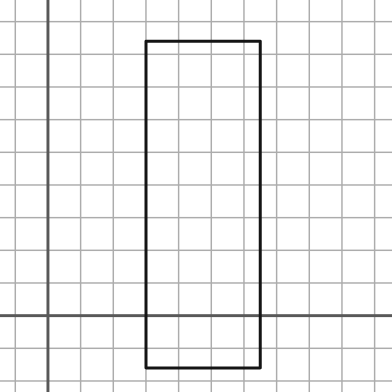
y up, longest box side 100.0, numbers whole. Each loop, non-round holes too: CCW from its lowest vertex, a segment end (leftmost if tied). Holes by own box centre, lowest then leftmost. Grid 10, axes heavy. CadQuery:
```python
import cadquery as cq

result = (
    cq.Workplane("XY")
    .moveTo(30.0, -16.0)
    .lineTo(65.0, -16.0)
    .lineTo(65.0, 84.0)
    .lineTo(30.0, 84.0)
    .close()
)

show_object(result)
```